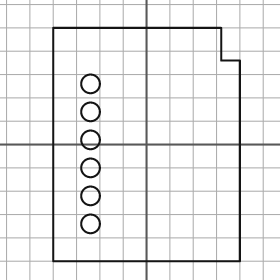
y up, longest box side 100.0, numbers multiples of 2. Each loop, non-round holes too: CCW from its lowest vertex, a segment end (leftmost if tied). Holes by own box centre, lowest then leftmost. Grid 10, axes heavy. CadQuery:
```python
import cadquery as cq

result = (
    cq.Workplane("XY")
    .moveTo(-40.0, -50.0)
    .lineTo(40.0, -50.0)
    .lineTo(40.0, 36.0)
    .lineTo(32.0, 36.0)
    .lineTo(32.0, 50.0)
    .lineTo(-40.0, 50.0)
    .close()
    .moveTo(-24.0, -34.0)
    .circle(4.0)
    .moveTo(-24.0, -22.0)
    .circle(4.0)
    .moveTo(-24.0, -10.0)
    .circle(4.0)
    .moveTo(-24.0, 2.0)
    .circle(4.0)
    .moveTo(-24.0, 14.0)
    .circle(4.0)
    .moveTo(-24.0, 26.0)
    .circle(4.0)
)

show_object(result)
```